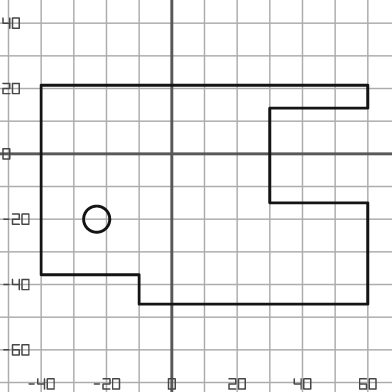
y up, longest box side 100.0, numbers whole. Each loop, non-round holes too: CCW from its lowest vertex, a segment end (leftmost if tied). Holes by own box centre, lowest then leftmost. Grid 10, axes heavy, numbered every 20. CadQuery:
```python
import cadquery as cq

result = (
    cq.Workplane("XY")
    .moveTo(-10.0, -46.0)
    .lineTo(60.0, -46.0)
    .lineTo(60.0, -15.0)
    .lineTo(30.0, -15.0)
    .lineTo(30.0, 14.0)
    .lineTo(60.0, 14.0)
    .lineTo(60.0, 21.0)
    .lineTo(-40.0, 21.0)
    .lineTo(-40.0, -37.0)
    .lineTo(-10.0, -37.0)
    .close()
    .moveTo(-23.0, -20.0)
    .circle(4.0)
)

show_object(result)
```